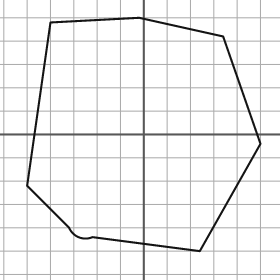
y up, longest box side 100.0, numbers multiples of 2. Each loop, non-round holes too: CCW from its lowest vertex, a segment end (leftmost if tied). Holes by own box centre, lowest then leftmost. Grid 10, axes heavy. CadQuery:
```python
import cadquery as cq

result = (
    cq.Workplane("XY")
    .moveTo(24.0, -50.0)
    .lineTo(50.0, -4.0)
    .lineTo(34.0, 42.0)
    .lineTo(-2.0, 50.0)
    .lineTo(-40.0, 48.0)
    .lineTo(-50.0, -22.0)
    .lineTo(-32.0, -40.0)
    .threePointArc((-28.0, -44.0), (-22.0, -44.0))
    .close()
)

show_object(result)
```